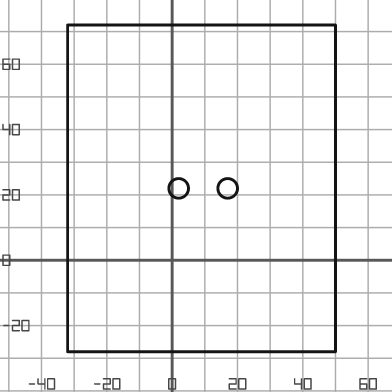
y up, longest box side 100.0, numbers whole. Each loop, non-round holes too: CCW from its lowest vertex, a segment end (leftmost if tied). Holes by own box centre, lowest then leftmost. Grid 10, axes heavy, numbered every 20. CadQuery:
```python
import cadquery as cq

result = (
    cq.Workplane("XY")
    .moveTo(-32.0, -28.0)
    .lineTo(50.0, -28.0)
    .lineTo(50.0, 72.0)
    .lineTo(-32.0, 72.0)
    .close()
    .moveTo(2.0, 22.0)
    .circle(3.0)
    .moveTo(17.0, 22.0)
    .circle(3.0)
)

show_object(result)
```